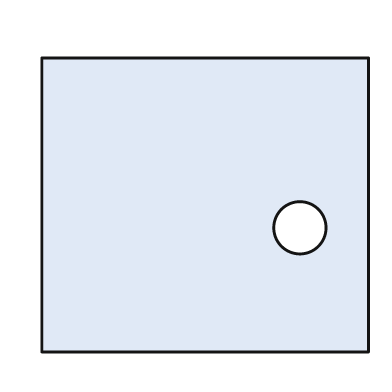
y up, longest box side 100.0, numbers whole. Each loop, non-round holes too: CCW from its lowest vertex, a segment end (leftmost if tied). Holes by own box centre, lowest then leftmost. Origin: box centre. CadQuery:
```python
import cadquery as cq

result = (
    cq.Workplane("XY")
    .moveTo(-50.0, -45.0)
    .lineTo(50.0, -45.0)
    .lineTo(50.0, 45.0)
    .lineTo(-50.0, 45.0)
    .close()
    .moveTo(29.0, -7.0)
    .circle(8.0)
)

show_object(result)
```